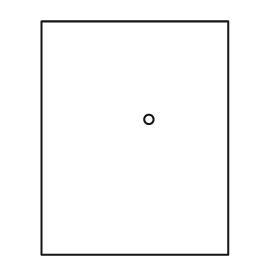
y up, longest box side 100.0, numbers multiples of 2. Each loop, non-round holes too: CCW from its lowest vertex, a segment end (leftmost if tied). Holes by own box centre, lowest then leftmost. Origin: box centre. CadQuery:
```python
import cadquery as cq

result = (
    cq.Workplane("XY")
    .moveTo(-40.0, -50.0)
    .lineTo(40.0, -50.0)
    .lineTo(40.0, 50.0)
    .lineTo(-40.0, 50.0)
    .close()
    .moveTo(6.0, 8.0)
    .circle(2.0)
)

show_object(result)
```